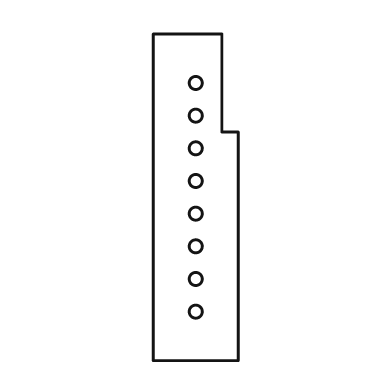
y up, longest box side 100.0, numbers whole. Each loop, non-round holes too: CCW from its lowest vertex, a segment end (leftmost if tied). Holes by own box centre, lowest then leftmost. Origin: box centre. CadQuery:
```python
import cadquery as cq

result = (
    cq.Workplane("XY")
    .moveTo(-13.0, -50.0)
    .lineTo(13.0, -50.0)
    .lineTo(13.0, 20.0)
    .lineTo(8.0, 20.0)
    .lineTo(8.0, 50.0)
    .lineTo(-13.0, 50.0)
    .close()
    .moveTo(0.0, -35.0)
    .circle(2.0)
    .moveTo(0.0, -25.0)
    .circle(2.0)
    .moveTo(0.0, -15.0)
    .circle(2.0)
    .moveTo(0.0, -5.0)
    .circle(2.0)
    .moveTo(0.0, 5.0)
    .circle(2.0)
    .moveTo(0.0, 15.0)
    .circle(2.0)
    .moveTo(0.0, 25.0)
    .circle(2.0)
    .moveTo(0.0, 35.0)
    .circle(2.0)
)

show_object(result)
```